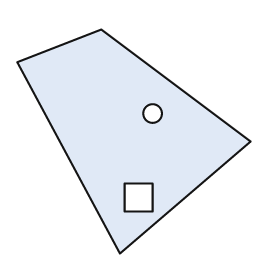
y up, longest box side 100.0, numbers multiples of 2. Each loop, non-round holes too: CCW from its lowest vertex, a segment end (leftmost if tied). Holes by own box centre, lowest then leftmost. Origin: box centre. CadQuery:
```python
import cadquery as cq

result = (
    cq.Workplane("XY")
    .moveTo(-6.0, -48.0)
    .lineTo(50.0, 0.0)
    .lineTo(-14.0, 48.0)
    .lineTo(-50.0, 34.0)
    .close()
    .moveTo(-4.0, -30.0)
    .lineTo(8.0, -30.0)
    .lineTo(8.0, -18.0)
    .lineTo(-4.0, -18.0)
    .close()
    .moveTo(8.0, 12.0)
    .circle(4.0)
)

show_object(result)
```